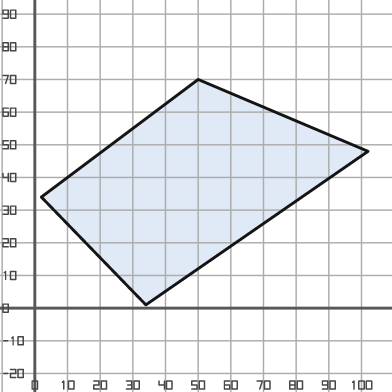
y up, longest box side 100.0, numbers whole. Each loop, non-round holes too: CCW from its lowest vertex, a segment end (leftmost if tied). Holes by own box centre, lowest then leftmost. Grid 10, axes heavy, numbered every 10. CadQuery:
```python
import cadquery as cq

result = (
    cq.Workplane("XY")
    .moveTo(34.0, 1.0)
    .lineTo(102.0, 48.0)
    .lineTo(50.0, 70.0)
    .lineTo(2.0, 34.0)
    .close()
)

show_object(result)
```